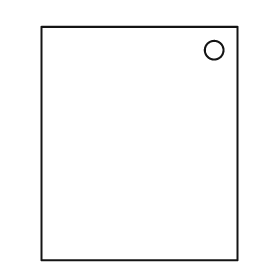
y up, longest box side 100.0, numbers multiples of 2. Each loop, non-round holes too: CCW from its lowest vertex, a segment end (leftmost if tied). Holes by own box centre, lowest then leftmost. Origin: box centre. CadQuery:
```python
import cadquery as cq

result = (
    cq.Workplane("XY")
    .moveTo(-42.0, -50.0)
    .lineTo(42.0, -50.0)
    .lineTo(42.0, 50.0)
    .lineTo(-42.0, 50.0)
    .close()
    .moveTo(32.0, 40.0)
    .circle(4.0)
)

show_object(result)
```